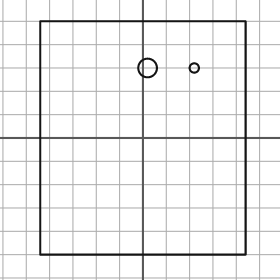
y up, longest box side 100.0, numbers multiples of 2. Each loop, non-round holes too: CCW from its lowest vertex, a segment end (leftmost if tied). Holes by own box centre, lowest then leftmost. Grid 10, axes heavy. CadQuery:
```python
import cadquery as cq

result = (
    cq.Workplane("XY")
    .moveTo(-44.0, -50.0)
    .lineTo(44.0, -50.0)
    .lineTo(44.0, 50.0)
    .lineTo(-44.0, 50.0)
    .close()
    .moveTo(2.0, 30.0)
    .circle(4.0)
    .moveTo(22.0, 30.0)
    .circle(2.0)
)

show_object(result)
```